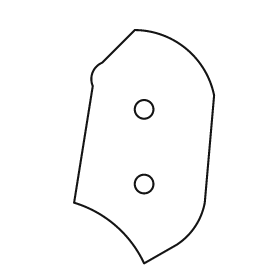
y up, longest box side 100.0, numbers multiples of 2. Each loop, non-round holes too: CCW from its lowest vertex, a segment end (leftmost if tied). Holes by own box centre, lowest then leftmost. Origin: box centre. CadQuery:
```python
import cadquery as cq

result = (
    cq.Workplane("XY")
    .moveTo(0.0, -50.0)
    .lineTo(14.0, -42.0)
    .threePointArc((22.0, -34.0), (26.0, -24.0))
    .lineTo(30.0, 22.0)
    .threePointArc((18.0, 42.0), (-4.0, 50.0))
    .lineTo(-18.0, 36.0)
    .threePointArc((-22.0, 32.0), (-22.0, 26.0))
    .lineTo(-30.0, -24.0)
    .threePointArc((-12.0, -34.0), (0.0, -50.0))
    .close()
    .moveTo(0.0, -16.0)
    .circle(4.0)
    .moveTo(0.0, 16.0)
    .circle(4.0)
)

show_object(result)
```